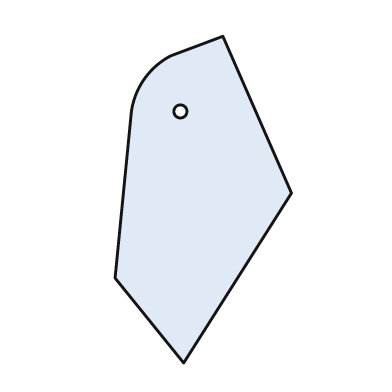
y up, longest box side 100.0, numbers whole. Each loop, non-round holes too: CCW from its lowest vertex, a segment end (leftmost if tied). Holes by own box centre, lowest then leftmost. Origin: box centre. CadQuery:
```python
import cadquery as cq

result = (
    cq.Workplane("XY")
    .moveTo(-6.0, -50.0)
    .lineTo(27.0, 2.0)
    .lineTo(6.0, 50.0)
    .lineTo(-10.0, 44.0)
    .threePointArc((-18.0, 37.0), (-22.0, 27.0))
    .lineTo(-27.0, -24.0)
    .close()
    .moveTo(-7.0, 27.0)
    .circle(2.0)
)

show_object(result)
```